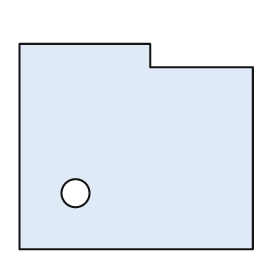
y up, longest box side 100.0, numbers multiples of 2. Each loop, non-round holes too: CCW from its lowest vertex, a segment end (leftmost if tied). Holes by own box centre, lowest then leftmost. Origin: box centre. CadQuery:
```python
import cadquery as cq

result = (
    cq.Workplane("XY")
    .moveTo(-50.0, -44.0)
    .lineTo(50.0, -44.0)
    .lineTo(50.0, 34.0)
    .lineTo(6.0, 34.0)
    .lineTo(6.0, 44.0)
    .lineTo(-50.0, 44.0)
    .close()
    .moveTo(-26.0, -20.0)
    .circle(6.0)
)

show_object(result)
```